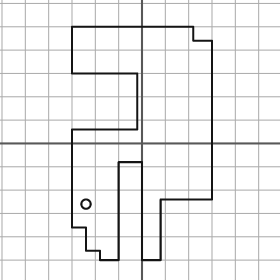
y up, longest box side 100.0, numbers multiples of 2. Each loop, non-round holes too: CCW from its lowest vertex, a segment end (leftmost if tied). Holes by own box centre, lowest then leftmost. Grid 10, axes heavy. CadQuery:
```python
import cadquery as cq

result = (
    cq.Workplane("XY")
    .moveTo(-18.0, -50.0)
    .lineTo(-10.0, -50.0)
    .lineTo(-10.0, -8.0)
    .lineTo(0.0, -8.0)
    .lineTo(0.0, -50.0)
    .lineTo(8.0, -50.0)
    .lineTo(8.0, -24.0)
    .lineTo(30.0, -24.0)
    .lineTo(30.0, 44.0)
    .lineTo(22.0, 44.0)
    .lineTo(22.0, 50.0)
    .lineTo(-30.0, 50.0)
    .lineTo(-30.0, 30.0)
    .lineTo(-2.0, 30.0)
    .lineTo(-2.0, 6.0)
    .lineTo(-30.0, 6.0)
    .lineTo(-30.0, -36.0)
    .lineTo(-24.0, -36.0)
    .lineTo(-24.0, -46.0)
    .lineTo(-18.0, -46.0)
    .close()
    .moveTo(-24.0, -26.0)
    .circle(2.0)
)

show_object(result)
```